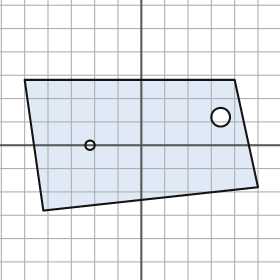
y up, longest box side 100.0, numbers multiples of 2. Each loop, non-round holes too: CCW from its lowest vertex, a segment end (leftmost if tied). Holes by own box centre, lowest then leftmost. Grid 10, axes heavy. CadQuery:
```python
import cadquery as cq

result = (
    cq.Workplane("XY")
    .moveTo(-42.0, -28.0)
    .lineTo(50.0, -18.0)
    .lineTo(40.0, 28.0)
    .lineTo(-50.0, 28.0)
    .close()
    .moveTo(-22.0, 0.0)
    .circle(2.0)
    .moveTo(34.0, 12.0)
    .circle(4.0)
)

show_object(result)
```